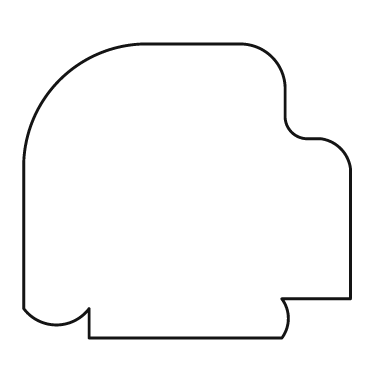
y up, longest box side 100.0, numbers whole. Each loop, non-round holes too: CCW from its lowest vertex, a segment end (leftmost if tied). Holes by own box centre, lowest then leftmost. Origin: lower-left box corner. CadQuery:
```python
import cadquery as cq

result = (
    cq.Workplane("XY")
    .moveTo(20.0, 0.0)
    .lineTo(79.0, 0.0)
    .threePointArc((81.0, 6.0), (79.0, 12.0))
    .lineTo(100.0, 12.0)
    .lineTo(100.0, 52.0)
    .threePointArc((97.0, 58.0), (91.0, 61.0))
    .lineTo(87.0, 61.0)
    .threePointArc((82.0, 63.0), (80.0, 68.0))
    .lineTo(80.0, 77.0)
    .threePointArc((76.0, 86.0), (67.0, 90.0))
    .lineTo(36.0, 90.0)
    .threePointArc((11.0, 79.0), (0.0, 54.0))
    .lineTo(0.0, 9.0)
    .threePointArc((10.0, 4.0), (20.0, 9.0))
    .close()
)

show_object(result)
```